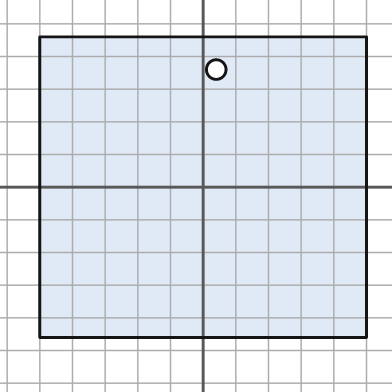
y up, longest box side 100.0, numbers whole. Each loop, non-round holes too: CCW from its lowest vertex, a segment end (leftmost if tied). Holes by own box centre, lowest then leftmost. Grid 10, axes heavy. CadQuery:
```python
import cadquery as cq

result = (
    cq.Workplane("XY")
    .moveTo(-50.0, -46.0)
    .lineTo(50.0, -46.0)
    .lineTo(50.0, 46.0)
    .lineTo(-50.0, 46.0)
    .close()
    .moveTo(4.0, 36.0)
    .circle(3.0)
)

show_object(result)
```